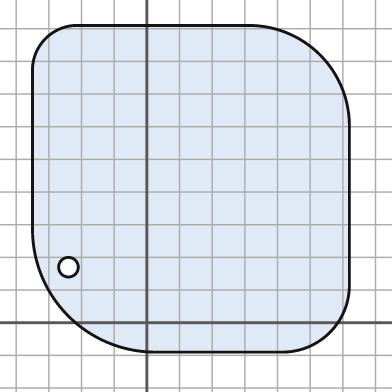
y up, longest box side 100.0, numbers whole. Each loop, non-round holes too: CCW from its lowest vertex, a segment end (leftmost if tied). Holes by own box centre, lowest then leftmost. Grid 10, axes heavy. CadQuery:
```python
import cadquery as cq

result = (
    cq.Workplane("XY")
    .moveTo(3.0, -9.0)
    .lineTo(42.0, -9.0)
    .threePointArc((56.0, -3.0), (62.0, 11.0))
    .lineTo(62.0, 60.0)
    .threePointArc((53.0, 82.0), (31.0, 91.0))
    .lineTo(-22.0, 91.0)
    .threePointArc((-31.0, 87.0), (-35.0, 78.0))
    .lineTo(-35.0, 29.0)
    .threePointArc((-24.0, 2.0), (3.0, -9.0))
    .close()
    .moveTo(-24.0, 17.0)
    .circle(3.0)
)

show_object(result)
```